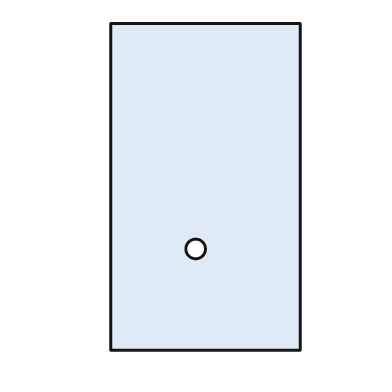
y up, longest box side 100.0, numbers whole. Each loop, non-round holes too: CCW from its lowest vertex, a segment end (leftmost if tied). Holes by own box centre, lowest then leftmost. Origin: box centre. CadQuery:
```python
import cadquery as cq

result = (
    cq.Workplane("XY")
    .moveTo(-29.0, -50.0)
    .lineTo(29.0, -50.0)
    .lineTo(29.0, 50.0)
    .lineTo(-29.0, 50.0)
    .close()
    .moveTo(-3.0, -19.0)
    .circle(3.0)
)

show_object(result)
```